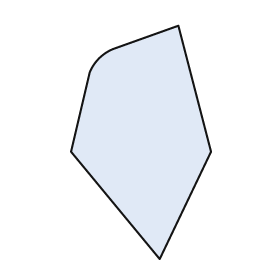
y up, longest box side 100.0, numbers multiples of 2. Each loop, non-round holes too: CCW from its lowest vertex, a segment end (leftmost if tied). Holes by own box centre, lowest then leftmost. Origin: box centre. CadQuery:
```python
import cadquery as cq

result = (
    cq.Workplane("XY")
    .moveTo(8.0, -50.0)
    .lineTo(30.0, -4.0)
    .lineTo(16.0, 50.0)
    .lineTo(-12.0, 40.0)
    .threePointArc((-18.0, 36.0), (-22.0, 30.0))
    .lineTo(-30.0, -4.0)
    .close()
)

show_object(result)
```